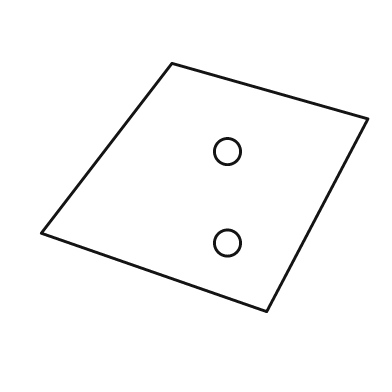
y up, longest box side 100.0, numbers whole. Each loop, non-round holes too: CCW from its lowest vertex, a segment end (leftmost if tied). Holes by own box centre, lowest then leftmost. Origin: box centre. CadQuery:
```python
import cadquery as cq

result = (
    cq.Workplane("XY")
    .moveTo(19.0, -38.0)
    .lineTo(50.0, 21.0)
    .lineTo(-10.0, 38.0)
    .lineTo(-50.0, -14.0)
    .close()
    .moveTo(7.0, -17.0)
    .circle(4.0)
    .moveTo(7.0, 11.0)
    .circle(4.0)
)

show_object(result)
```